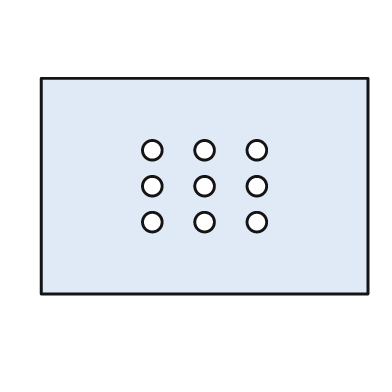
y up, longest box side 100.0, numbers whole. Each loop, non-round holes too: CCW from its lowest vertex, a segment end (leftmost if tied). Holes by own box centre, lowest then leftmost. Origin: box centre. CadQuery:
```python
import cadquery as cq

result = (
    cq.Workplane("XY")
    .moveTo(-50.0, -33.0)
    .lineTo(50.0, -33.0)
    .lineTo(50.0, 33.0)
    .lineTo(-50.0, 33.0)
    .close()
    .moveTo(-16.0, -11.0)
    .circle(3.0)
    .moveTo(0.0, -11.0)
    .circle(3.0)
    .moveTo(16.0, -11.0)
    .circle(3.0)
    .moveTo(-16.0, 0.0)
    .circle(3.0)
    .moveTo(0.0, 0.0)
    .circle(3.0)
    .moveTo(16.0, 0.0)
    .circle(3.0)
    .moveTo(-16.0, 11.0)
    .circle(3.0)
    .moveTo(0.0, 11.0)
    .circle(3.0)
    .moveTo(16.0, 11.0)
    .circle(3.0)
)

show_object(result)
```